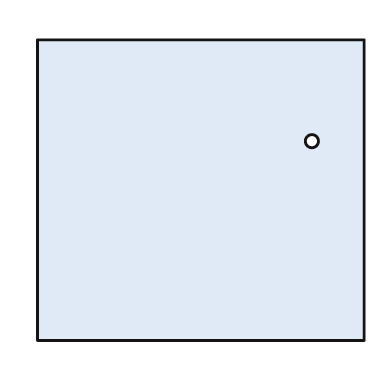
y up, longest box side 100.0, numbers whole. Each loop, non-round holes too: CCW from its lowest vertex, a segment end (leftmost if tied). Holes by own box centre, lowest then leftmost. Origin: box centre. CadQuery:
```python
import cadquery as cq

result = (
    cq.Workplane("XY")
    .moveTo(-50.0, -46.0)
    .lineTo(50.0, -46.0)
    .lineTo(50.0, 46.0)
    .lineTo(-50.0, 46.0)
    .close()
    .moveTo(34.0, 15.0)
    .circle(2.0)
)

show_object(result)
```